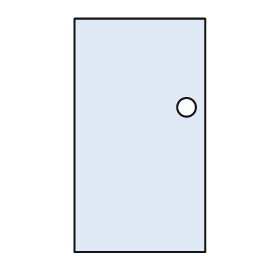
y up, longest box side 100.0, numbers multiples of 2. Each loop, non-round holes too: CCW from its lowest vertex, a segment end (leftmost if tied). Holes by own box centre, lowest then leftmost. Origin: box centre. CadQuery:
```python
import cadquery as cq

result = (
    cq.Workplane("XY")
    .moveTo(-28.0, -50.0)
    .lineTo(28.0, -50.0)
    .lineTo(28.0, 50.0)
    .lineTo(-28.0, 50.0)
    .close()
    .moveTo(20.0, 12.0)
    .circle(4.0)
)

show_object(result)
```